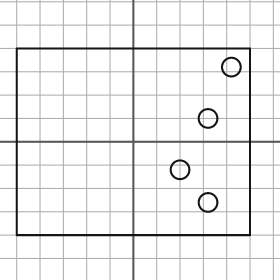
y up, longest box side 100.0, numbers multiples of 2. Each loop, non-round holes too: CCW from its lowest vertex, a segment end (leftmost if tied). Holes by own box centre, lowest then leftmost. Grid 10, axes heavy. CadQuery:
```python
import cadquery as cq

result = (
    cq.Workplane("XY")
    .moveTo(-50.0, -40.0)
    .lineTo(50.0, -40.0)
    .lineTo(50.0, 40.0)
    .lineTo(-50.0, 40.0)
    .close()
    .moveTo(32.0, -26.0)
    .circle(4.0)
    .moveTo(20.0, -12.0)
    .circle(4.0)
    .moveTo(32.0, 10.0)
    .circle(4.0)
    .moveTo(42.0, 32.0)
    .circle(4.0)
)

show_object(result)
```